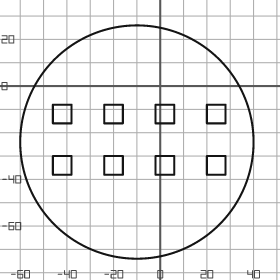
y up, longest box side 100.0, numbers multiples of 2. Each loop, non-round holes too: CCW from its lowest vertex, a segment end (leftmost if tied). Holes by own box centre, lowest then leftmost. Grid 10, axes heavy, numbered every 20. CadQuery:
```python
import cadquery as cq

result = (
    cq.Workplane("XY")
    .moveTo(-10.0, -24.0)
    .circle(50.0)
    .moveTo(-46.0, -38.0)
    .lineTo(-38.0, -38.0)
    .lineTo(-38.0, -30.0)
    .lineTo(-46.0, -30.0)
    .close()
    .moveTo(-24.0, -38.0)
    .lineTo(-16.0, -38.0)
    .lineTo(-16.0, -30.0)
    .lineTo(-24.0, -30.0)
    .close()
    .moveTo(-2.0, -38.0)
    .lineTo(6.0, -38.0)
    .lineTo(6.0, -30.0)
    .lineTo(-2.0, -30.0)
    .close()
    .moveTo(20.0, -38.0)
    .lineTo(28.0, -38.0)
    .lineTo(28.0, -30.0)
    .lineTo(20.0, -30.0)
    .close()
    .moveTo(-46.0, -16.0)
    .lineTo(-38.0, -16.0)
    .lineTo(-38.0, -8.0)
    .lineTo(-46.0, -8.0)
    .close()
    .moveTo(-24.0, -16.0)
    .lineTo(-16.0, -16.0)
    .lineTo(-16.0, -8.0)
    .lineTo(-24.0, -8.0)
    .close()
    .moveTo(-2.0, -16.0)
    .lineTo(6.0, -16.0)
    .lineTo(6.0, -8.0)
    .lineTo(-2.0, -8.0)
    .close()
    .moveTo(20.0, -16.0)
    .lineTo(28.0, -16.0)
    .lineTo(28.0, -8.0)
    .lineTo(20.0, -8.0)
    .close()
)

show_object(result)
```